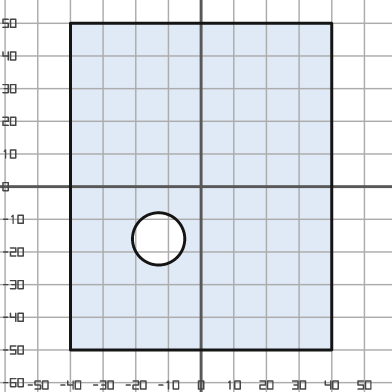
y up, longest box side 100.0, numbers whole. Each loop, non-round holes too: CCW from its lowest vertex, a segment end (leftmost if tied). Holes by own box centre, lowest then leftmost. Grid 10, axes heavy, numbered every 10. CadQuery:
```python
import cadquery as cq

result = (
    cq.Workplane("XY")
    .moveTo(-40.0, -50.0)
    .lineTo(40.0, -50.0)
    .lineTo(40.0, 50.0)
    .lineTo(-40.0, 50.0)
    .close()
    .moveTo(-13.0, -16.0)
    .circle(8.0)
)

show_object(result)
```